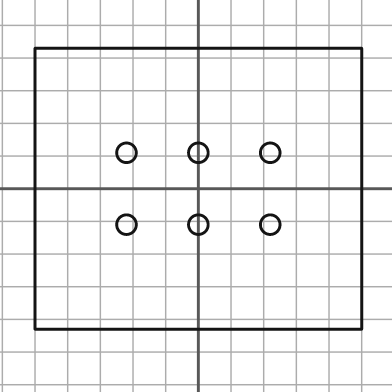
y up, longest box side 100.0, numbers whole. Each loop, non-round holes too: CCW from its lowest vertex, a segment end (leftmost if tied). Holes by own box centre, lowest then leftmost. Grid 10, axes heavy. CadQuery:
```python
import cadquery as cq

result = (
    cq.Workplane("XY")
    .moveTo(-50.0, -43.0)
    .lineTo(50.0, -43.0)
    .lineTo(50.0, 43.0)
    .lineTo(-50.0, 43.0)
    .close()
    .moveTo(-22.0, -11.0)
    .circle(3.0)
    .moveTo(0.0, -11.0)
    .circle(3.0)
    .moveTo(22.0, -11.0)
    .circle(3.0)
    .moveTo(-22.0, 11.0)
    .circle(3.0)
    .moveTo(0.0, 11.0)
    .circle(3.0)
    .moveTo(22.0, 11.0)
    .circle(3.0)
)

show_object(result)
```